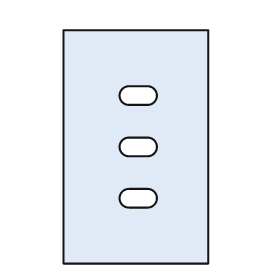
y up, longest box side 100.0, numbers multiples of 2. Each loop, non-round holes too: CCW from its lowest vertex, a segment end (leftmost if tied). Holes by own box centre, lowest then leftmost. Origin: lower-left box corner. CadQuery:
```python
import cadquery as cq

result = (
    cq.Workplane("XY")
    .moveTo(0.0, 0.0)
    .lineTo(62.0, 0.0)
    .lineTo(62.0, 100.0)
    .lineTo(0.0, 100.0)
    .close()
    .moveTo(28.0, 24.0)
    .lineTo(36.0, 24.0)
    .threePointArc((40.0, 28.0), (36.0, 32.0))
    .lineTo(28.0, 32.0)
    .threePointArc((24.0, 28.0), (28.0, 24.0))
    .close()
    .moveTo(28.0, 46.0)
    .lineTo(36.0, 46.0)
    .threePointArc((40.0, 50.0), (36.0, 54.0))
    .lineTo(28.0, 54.0)
    .threePointArc((24.0, 50.0), (28.0, 46.0))
    .close()
    .moveTo(28.0, 68.0)
    .lineTo(36.0, 68.0)
    .threePointArc((40.0, 72.0), (36.0, 76.0))
    .lineTo(28.0, 76.0)
    .threePointArc((24.0, 72.0), (28.0, 68.0))
    .close()
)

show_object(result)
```